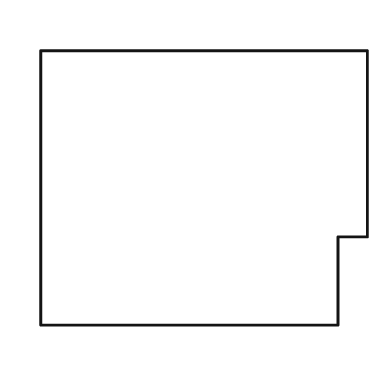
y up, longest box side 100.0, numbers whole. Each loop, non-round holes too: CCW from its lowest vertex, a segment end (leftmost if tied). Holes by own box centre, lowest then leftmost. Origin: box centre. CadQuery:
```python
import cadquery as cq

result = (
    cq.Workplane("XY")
    .moveTo(-50.0, -42.0)
    .lineTo(41.0, -42.0)
    .lineTo(41.0, -15.0)
    .lineTo(50.0, -15.0)
    .lineTo(50.0, 42.0)
    .lineTo(-50.0, 42.0)
    .close()
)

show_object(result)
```